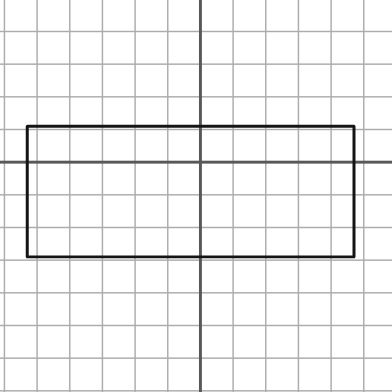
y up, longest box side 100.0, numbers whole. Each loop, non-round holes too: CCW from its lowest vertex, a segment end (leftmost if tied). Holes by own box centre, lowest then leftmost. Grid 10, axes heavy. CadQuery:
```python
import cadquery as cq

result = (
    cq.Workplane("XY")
    .moveTo(-53.0, -29.0)
    .lineTo(47.0, -29.0)
    .lineTo(47.0, 11.0)
    .lineTo(-53.0, 11.0)
    .close()
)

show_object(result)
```